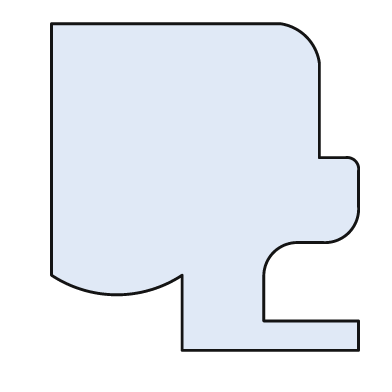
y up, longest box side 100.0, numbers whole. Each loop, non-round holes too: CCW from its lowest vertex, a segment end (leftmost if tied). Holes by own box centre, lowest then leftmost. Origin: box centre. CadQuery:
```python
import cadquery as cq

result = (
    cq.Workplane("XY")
    .moveTo(-7.0, -50.0)
    .lineTo(47.0, -50.0)
    .lineTo(47.0, -41.0)
    .lineTo(18.0, -41.0)
    .lineTo(18.0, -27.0)
    .threePointArc((21.0, -20.0), (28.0, -17.0))
    .lineTo(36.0, -17.0)
    .threePointArc((44.0, -14.0), (47.0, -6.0))
    .lineTo(47.0, 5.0)
    .threePointArc((46.0, 8.0), (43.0, 9.0))
    .lineTo(35.0, 9.0)
    .lineTo(35.0, 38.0)
    .threePointArc((31.0, 46.0), (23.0, 50.0))
    .lineTo(-47.0, 50.0)
    .lineTo(-47.0, -27.0)
    .threePointArc((-27.0, -33.0), (-7.0, -27.0))
    .close()
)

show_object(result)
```